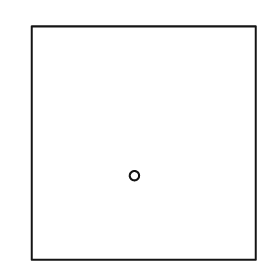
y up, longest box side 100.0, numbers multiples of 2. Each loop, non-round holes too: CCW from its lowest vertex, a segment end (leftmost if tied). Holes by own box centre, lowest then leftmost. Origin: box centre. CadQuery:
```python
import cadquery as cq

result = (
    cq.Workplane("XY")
    .moveTo(-48.0, -50.0)
    .lineTo(48.0, -50.0)
    .lineTo(48.0, 50.0)
    .lineTo(-48.0, 50.0)
    .close()
    .moveTo(-4.0, -14.0)
    .circle(2.0)
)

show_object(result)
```